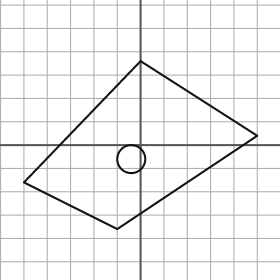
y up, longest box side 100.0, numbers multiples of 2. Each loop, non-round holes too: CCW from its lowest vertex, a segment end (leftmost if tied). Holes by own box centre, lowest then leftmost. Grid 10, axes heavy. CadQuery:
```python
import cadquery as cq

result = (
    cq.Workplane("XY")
    .moveTo(-10.0, -36.0)
    .lineTo(50.0, 4.0)
    .lineTo(0.0, 36.0)
    .lineTo(-50.0, -16.0)
    .close()
    .moveTo(-4.0, -6.0)
    .circle(6.0)
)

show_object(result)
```